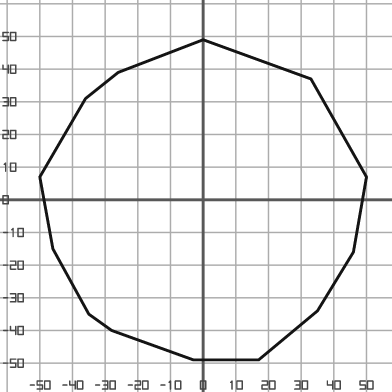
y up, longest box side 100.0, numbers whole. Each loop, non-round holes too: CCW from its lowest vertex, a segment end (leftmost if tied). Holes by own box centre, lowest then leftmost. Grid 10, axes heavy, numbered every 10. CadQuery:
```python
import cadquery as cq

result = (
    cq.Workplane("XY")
    .moveTo(-3.0, -49.0)
    .lineTo(17.0, -49.0)
    .lineTo(35.0, -34.0)
    .lineTo(46.0, -16.0)
    .lineTo(50.0, 7.0)
    .lineTo(33.0, 37.0)
    .lineTo(0.0, 49.0)
    .lineTo(-26.0, 39.0)
    .lineTo(-36.0, 31.0)
    .lineTo(-50.0, 7.0)
    .lineTo(-46.0, -15.0)
    .lineTo(-35.0, -35.0)
    .lineTo(-28.0, -40.0)
    .close()
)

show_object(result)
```